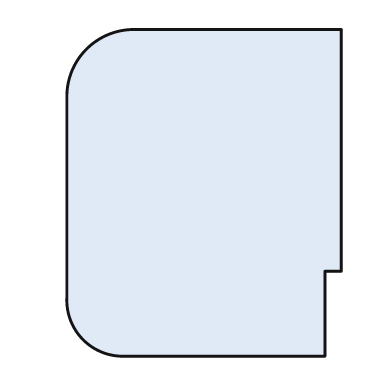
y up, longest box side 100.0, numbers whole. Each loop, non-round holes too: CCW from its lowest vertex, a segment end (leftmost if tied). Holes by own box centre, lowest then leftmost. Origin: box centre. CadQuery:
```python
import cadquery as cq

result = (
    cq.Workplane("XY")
    .moveTo(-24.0, -50.0)
    .lineTo(37.0, -50.0)
    .lineTo(37.0, -24.0)
    .lineTo(42.0, -24.0)
    .lineTo(42.0, 50.0)
    .lineTo(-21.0, 50.0)
    .threePointArc((-36.0, 44.0), (-42.0, 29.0))
    .lineTo(-42.0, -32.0)
    .threePointArc((-37.0, -45.0), (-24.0, -50.0))
    .close()
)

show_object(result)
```